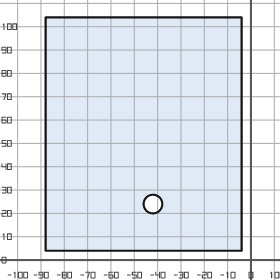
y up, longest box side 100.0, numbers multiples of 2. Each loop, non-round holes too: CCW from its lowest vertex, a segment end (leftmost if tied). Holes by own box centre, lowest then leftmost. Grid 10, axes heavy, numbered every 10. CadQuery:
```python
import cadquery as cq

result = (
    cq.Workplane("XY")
    .moveTo(-88.0, 4.0)
    .lineTo(-4.0, 4.0)
    .lineTo(-4.0, 104.0)
    .lineTo(-88.0, 104.0)
    .close()
    .moveTo(-42.0, 24.0)
    .circle(4.0)
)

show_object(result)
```